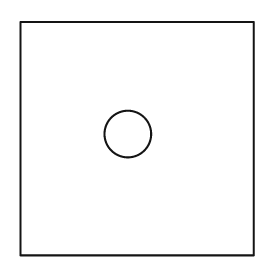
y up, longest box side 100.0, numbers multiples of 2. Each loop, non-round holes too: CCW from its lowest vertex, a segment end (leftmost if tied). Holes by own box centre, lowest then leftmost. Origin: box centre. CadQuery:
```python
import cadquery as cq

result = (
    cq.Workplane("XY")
    .moveTo(-50.0, -50.0)
    .lineTo(50.0, -50.0)
    .lineTo(50.0, 50.0)
    .lineTo(-50.0, 50.0)
    .close()
    .moveTo(-4.0, 2.0)
    .circle(10.0)
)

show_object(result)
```